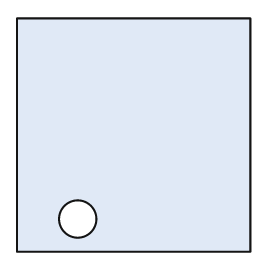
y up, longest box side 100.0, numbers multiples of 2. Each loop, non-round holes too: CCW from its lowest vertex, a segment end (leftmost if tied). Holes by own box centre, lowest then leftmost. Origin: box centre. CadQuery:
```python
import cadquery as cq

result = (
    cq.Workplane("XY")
    .moveTo(-50.0, -50.0)
    .lineTo(50.0, -50.0)
    .lineTo(50.0, 50.0)
    .lineTo(-50.0, 50.0)
    .close()
    .moveTo(-24.0, -36.0)
    .circle(8.0)
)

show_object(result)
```